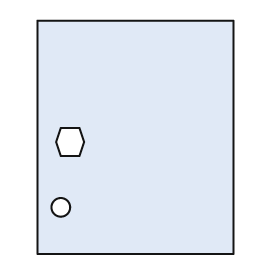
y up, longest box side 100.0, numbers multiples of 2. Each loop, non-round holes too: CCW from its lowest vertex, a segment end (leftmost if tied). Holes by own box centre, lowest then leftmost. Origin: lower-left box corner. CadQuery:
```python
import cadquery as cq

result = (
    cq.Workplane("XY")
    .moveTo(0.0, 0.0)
    .lineTo(84.0, 0.0)
    .lineTo(84.0, 100.0)
    .lineTo(0.0, 100.0)
    .close()
    .moveTo(10.0, 20.0)
    .circle(4.0)
    .moveTo(10.0, 42.0)
    .lineTo(18.0, 42.0)
    .lineTo(20.0, 48.0)
    .lineTo(18.0, 54.0)
    .lineTo(10.0, 54.0)
    .lineTo(8.0, 48.0)
    .close()
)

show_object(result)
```